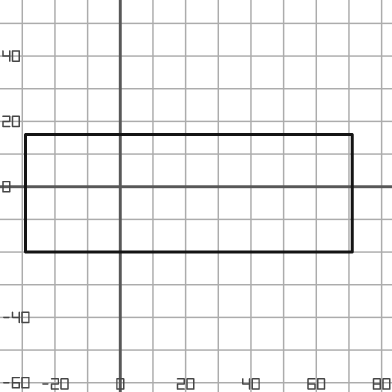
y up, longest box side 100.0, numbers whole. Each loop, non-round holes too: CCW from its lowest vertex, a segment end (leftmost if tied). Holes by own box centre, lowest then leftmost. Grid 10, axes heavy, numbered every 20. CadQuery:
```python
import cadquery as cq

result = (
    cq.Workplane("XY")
    .moveTo(-29.0, -20.0)
    .lineTo(71.0, -20.0)
    .lineTo(71.0, 16.0)
    .lineTo(-29.0, 16.0)
    .close()
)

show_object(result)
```